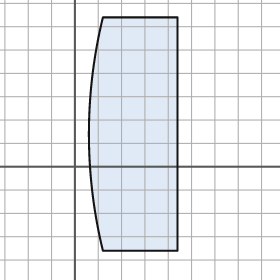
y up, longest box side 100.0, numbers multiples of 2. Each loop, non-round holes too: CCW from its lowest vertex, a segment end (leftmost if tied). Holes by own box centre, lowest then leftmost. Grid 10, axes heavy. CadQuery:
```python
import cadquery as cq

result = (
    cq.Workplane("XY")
    .moveTo(12.0, -36.0)
    .lineTo(44.0, -36.0)
    .lineTo(44.0, 64.0)
    .lineTo(12.0, 64.0)
    .threePointArc((6.0, 14.0), (12.0, -36.0))
    .close()
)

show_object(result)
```